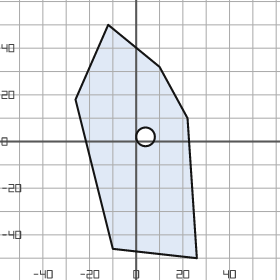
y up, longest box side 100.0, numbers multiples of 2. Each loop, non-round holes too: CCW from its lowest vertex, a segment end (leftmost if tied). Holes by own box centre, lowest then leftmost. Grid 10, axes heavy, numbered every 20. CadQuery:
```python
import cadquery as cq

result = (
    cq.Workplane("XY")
    .moveTo(26.0, -50.0)
    .lineTo(22.0, 10.0)
    .lineTo(10.0, 32.0)
    .lineTo(-12.0, 50.0)
    .lineTo(-26.0, 18.0)
    .lineTo(-10.0, -46.0)
    .close()
    .moveTo(4.0, 2.0)
    .circle(4.0)
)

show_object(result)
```